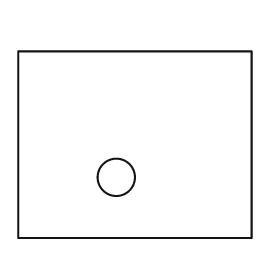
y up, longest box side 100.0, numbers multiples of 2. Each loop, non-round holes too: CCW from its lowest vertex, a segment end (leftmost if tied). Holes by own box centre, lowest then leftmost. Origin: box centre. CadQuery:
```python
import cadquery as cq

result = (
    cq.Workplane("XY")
    .moveTo(-50.0, -40.0)
    .lineTo(50.0, -40.0)
    .lineTo(50.0, 40.0)
    .lineTo(-50.0, 40.0)
    .close()
    .moveTo(-8.0, -14.0)
    .circle(8.0)
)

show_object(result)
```